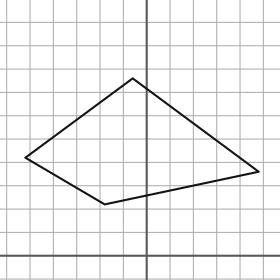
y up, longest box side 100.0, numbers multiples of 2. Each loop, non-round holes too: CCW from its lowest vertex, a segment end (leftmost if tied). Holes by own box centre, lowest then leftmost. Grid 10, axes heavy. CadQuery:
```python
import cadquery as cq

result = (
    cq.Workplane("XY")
    .moveTo(-18.0, 22.0)
    .lineTo(48.0, 36.0)
    .lineTo(-6.0, 76.0)
    .lineTo(-52.0, 42.0)
    .close()
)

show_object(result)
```